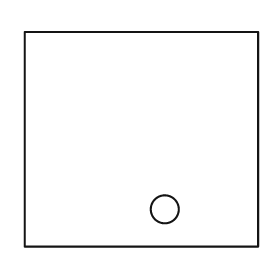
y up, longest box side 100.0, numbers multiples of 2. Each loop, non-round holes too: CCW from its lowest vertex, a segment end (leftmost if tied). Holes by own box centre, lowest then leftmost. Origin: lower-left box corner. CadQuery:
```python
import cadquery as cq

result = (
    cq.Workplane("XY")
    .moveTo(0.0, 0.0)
    .lineTo(100.0, 0.0)
    .lineTo(100.0, 92.0)
    .lineTo(0.0, 92.0)
    .close()
    .moveTo(60.0, 16.0)
    .circle(6.0)
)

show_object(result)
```